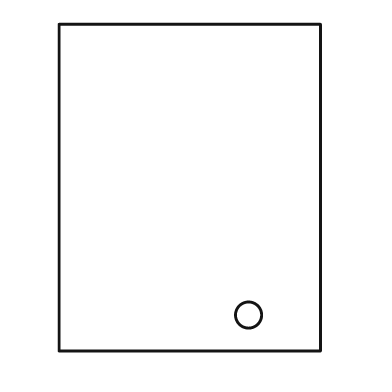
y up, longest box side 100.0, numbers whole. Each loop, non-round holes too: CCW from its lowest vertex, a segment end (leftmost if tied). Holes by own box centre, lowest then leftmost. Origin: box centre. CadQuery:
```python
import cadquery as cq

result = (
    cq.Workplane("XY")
    .moveTo(-40.0, -50.0)
    .lineTo(40.0, -50.0)
    .lineTo(40.0, 50.0)
    .lineTo(-40.0, 50.0)
    .close()
    .moveTo(18.0, -39.0)
    .circle(4.0)
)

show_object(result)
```